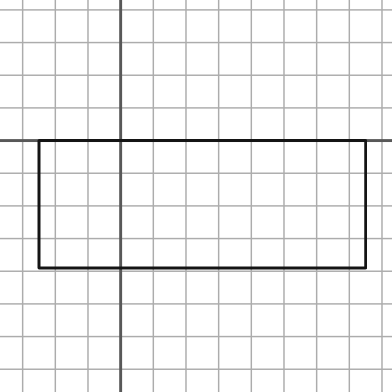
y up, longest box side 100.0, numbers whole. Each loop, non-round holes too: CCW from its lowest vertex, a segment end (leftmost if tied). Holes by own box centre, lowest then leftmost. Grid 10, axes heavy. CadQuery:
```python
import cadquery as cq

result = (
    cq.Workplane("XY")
    .moveTo(-25.0, -39.0)
    .lineTo(75.0, -39.0)
    .lineTo(75.0, 0.0)
    .lineTo(-25.0, 0.0)
    .close()
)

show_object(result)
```